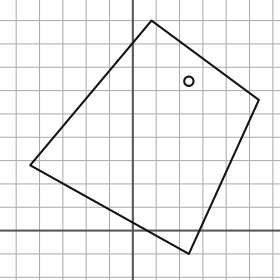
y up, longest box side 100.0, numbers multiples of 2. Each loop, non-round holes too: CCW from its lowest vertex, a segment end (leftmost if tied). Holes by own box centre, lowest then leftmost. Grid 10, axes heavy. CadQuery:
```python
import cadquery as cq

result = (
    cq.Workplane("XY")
    .moveTo(24.0, -10.0)
    .lineTo(54.0, 56.0)
    .lineTo(8.0, 90.0)
    .lineTo(-44.0, 28.0)
    .close()
    .moveTo(24.0, 64.0)
    .circle(2.0)
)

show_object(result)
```